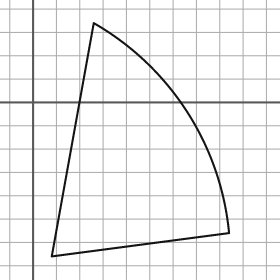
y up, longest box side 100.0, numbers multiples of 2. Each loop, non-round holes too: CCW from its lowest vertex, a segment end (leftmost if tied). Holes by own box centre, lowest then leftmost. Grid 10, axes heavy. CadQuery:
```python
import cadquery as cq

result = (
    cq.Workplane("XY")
    .moveTo(8.0, -66.0)
    .lineTo(84.0, -56.0)
    .threePointArc((66.0, -4.0), (26.0, 34.0))
    .close()
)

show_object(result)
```